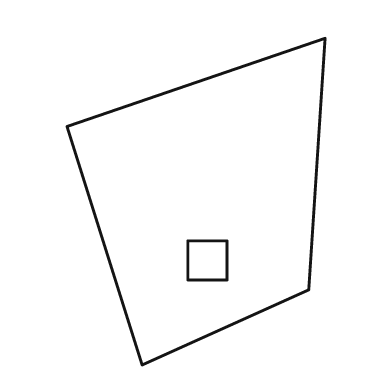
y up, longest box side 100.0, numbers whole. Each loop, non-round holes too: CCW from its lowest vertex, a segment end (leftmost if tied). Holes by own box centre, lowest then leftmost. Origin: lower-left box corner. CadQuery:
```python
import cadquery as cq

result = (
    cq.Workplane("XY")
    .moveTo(23.0, 0.0)
    .lineTo(74.0, 23.0)
    .lineTo(79.0, 100.0)
    .lineTo(0.0, 73.0)
    .close()
    .moveTo(37.0, 26.0)
    .lineTo(49.0, 26.0)
    .lineTo(49.0, 38.0)
    .lineTo(37.0, 38.0)
    .close()
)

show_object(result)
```